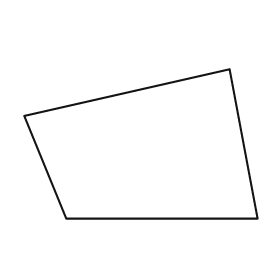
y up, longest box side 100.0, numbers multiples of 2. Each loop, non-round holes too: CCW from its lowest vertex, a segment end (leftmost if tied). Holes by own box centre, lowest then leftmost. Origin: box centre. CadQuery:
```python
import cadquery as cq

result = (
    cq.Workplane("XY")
    .moveTo(-32.0, -32.0)
    .lineTo(50.0, -32.0)
    .lineTo(38.0, 32.0)
    .lineTo(-50.0, 12.0)
    .close()
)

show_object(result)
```